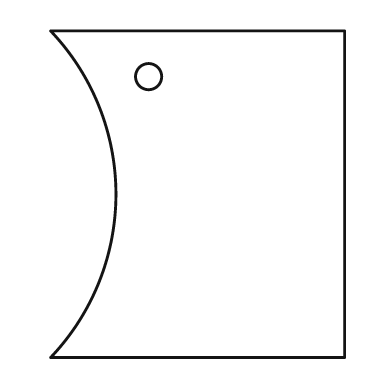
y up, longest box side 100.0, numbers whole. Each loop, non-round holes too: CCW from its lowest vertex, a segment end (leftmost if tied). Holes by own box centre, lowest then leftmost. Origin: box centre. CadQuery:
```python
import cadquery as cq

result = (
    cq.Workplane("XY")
    .moveTo(-45.0, -50.0)
    .lineTo(45.0, -50.0)
    .lineTo(45.0, 50.0)
    .lineTo(-45.0, 50.0)
    .threePointArc((-25.0, 0.0), (-45.0, -50.0))
    .close()
    .moveTo(-15.0, 36.0)
    .circle(4.0)
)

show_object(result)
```